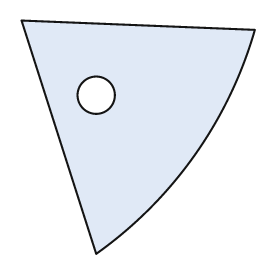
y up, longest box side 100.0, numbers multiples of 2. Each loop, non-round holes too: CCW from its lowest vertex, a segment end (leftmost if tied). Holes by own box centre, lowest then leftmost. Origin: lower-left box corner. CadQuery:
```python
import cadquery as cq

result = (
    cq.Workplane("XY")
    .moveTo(32.0, 0.0)
    .threePointArc((74.0, 42.0), (100.0, 96.0))
    .lineTo(0.0, 100.0)
    .close()
    .moveTo(32.0, 68.0)
    .circle(8.0)
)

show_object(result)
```